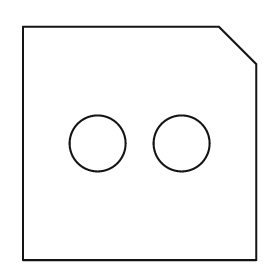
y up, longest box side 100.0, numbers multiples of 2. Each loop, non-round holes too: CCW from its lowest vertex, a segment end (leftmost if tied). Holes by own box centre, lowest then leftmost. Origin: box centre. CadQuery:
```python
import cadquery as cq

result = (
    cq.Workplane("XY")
    .moveTo(-50.0, -50.0)
    .lineTo(50.0, -50.0)
    .lineTo(50.0, 34.0)
    .lineTo(34.0, 50.0)
    .lineTo(-50.0, 50.0)
    .close()
    .moveTo(-18.0, 0.0)
    .circle(12.0)
    .moveTo(18.0, 0.0)
    .circle(12.0)
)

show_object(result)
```